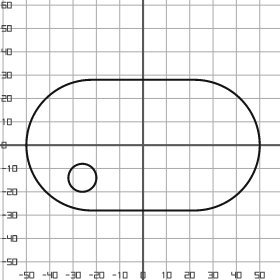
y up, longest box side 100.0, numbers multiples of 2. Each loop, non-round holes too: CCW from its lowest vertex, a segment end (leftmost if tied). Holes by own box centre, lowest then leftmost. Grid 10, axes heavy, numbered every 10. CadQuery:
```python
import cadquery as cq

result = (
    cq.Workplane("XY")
    .moveTo(-22.0, -28.0)
    .lineTo(22.0, -28.0)
    .threePointArc((50.0, 0.0), (22.0, 28.0))
    .lineTo(-22.0, 28.0)
    .threePointArc((-50.0, 0.0), (-22.0, -28.0))
    .close()
    .moveTo(-26.0, -14.0)
    .circle(6.0)
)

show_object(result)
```